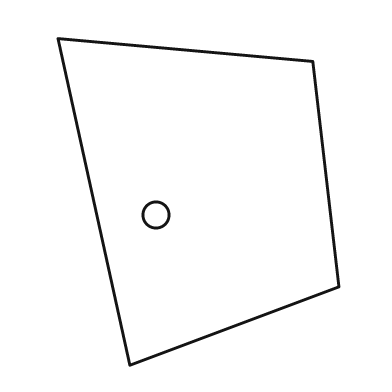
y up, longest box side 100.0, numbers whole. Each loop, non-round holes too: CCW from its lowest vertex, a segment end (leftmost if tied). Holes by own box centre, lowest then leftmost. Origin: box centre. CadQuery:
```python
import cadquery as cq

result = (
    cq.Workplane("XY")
    .moveTo(-21.0, -50.0)
    .lineTo(43.0, -26.0)
    .lineTo(35.0, 43.0)
    .lineTo(-43.0, 50.0)
    .close()
    .moveTo(-13.0, -4.0)
    .circle(4.0)
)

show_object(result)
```